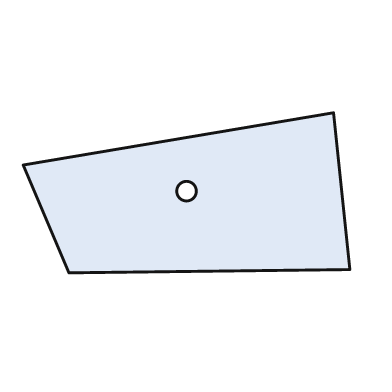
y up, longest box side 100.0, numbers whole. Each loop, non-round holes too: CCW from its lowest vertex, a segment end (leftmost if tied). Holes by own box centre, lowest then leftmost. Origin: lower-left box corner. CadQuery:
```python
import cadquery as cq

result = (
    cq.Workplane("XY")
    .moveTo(14.0, 0.0)
    .lineTo(100.0, 1.0)
    .lineTo(95.0, 49.0)
    .lineTo(0.0, 33.0)
    .close()
    .moveTo(50.0, 25.0)
    .circle(3.0)
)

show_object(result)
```